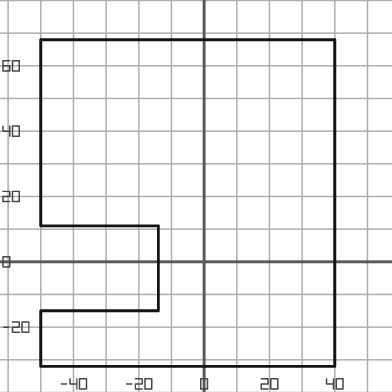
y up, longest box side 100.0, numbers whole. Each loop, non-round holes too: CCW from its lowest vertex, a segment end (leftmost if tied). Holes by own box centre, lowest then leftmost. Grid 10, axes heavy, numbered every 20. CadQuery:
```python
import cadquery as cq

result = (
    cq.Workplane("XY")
    .moveTo(-50.0, -32.0)
    .lineTo(40.0, -32.0)
    .lineTo(40.0, 68.0)
    .lineTo(-50.0, 68.0)
    .lineTo(-50.0, 11.0)
    .lineTo(-14.0, 11.0)
    .lineTo(-14.0, -15.0)
    .lineTo(-50.0, -15.0)
    .close()
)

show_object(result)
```